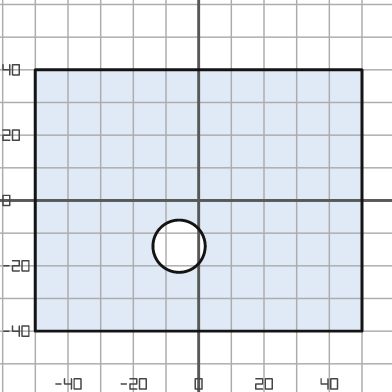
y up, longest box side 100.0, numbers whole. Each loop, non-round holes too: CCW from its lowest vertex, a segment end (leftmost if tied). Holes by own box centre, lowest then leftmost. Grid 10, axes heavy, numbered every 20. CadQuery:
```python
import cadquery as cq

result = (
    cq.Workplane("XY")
    .moveTo(-50.0, -40.0)
    .lineTo(50.0, -40.0)
    .lineTo(50.0, 40.0)
    .lineTo(-50.0, 40.0)
    .close()
    .moveTo(-6.0, -14.0)
    .circle(8.0)
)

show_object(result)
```